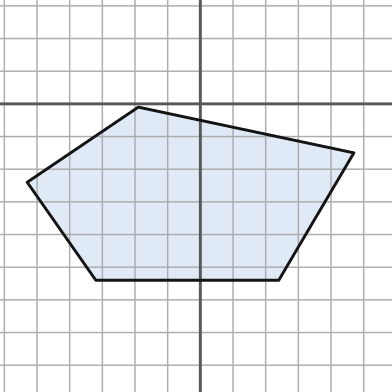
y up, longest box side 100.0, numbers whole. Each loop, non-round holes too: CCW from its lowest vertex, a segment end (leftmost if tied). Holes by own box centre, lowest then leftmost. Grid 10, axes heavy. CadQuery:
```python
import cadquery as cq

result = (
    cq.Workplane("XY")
    .moveTo(-32.0, -54.0)
    .lineTo(24.0, -54.0)
    .lineTo(47.0, -15.0)
    .lineTo(-19.0, -1.0)
    .lineTo(-53.0, -24.0)
    .close()
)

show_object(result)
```